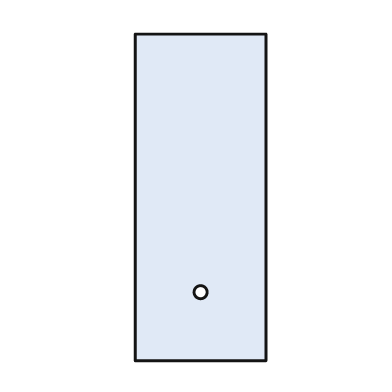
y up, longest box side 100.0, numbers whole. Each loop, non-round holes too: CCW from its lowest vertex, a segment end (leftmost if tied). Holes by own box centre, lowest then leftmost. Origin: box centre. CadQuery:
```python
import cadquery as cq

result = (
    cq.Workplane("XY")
    .moveTo(-20.0, -50.0)
    .lineTo(20.0, -50.0)
    .lineTo(20.0, 50.0)
    .lineTo(-20.0, 50.0)
    .close()
    .moveTo(0.0, -29.0)
    .circle(2.0)
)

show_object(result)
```